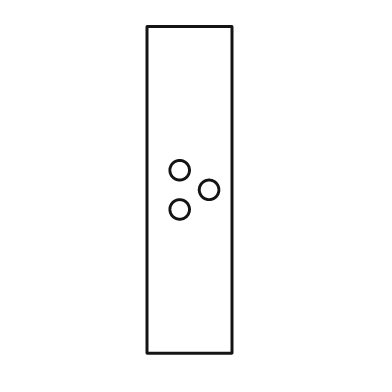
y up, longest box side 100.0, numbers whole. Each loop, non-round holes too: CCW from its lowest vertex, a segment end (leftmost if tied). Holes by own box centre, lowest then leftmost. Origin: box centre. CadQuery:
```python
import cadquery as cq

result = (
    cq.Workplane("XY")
    .moveTo(-13.0, -50.0)
    .lineTo(13.0, -50.0)
    .lineTo(13.0, 50.0)
    .lineTo(-13.0, 50.0)
    .close()
    .moveTo(-3.0, -6.0)
    .circle(3.0)
    .moveTo(6.0, 0.0)
    .circle(3.0)
    .moveTo(-3.0, 6.0)
    .circle(3.0)
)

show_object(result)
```